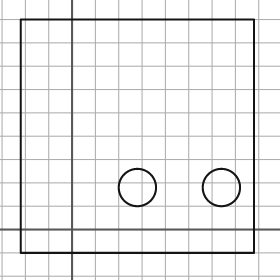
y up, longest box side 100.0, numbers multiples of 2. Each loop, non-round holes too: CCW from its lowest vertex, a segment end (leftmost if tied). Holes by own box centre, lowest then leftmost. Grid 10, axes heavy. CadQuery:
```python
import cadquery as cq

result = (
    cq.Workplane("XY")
    .moveTo(-22.0, -10.0)
    .lineTo(78.0, -10.0)
    .lineTo(78.0, 90.0)
    .lineTo(-22.0, 90.0)
    .close()
    .moveTo(28.0, 18.0)
    .circle(8.0)
    .moveTo(64.0, 18.0)
    .circle(8.0)
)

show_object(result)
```